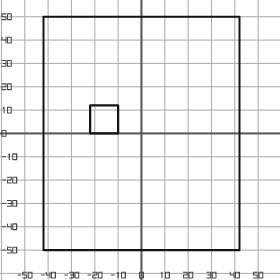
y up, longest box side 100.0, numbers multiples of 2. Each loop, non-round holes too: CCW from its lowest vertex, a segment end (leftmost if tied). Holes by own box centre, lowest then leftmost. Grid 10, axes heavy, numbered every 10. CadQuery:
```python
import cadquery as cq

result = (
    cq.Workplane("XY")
    .moveTo(-42.0, -50.0)
    .lineTo(42.0, -50.0)
    .lineTo(42.0, 50.0)
    .lineTo(-42.0, 50.0)
    .close()
    .moveTo(-22.0, 0.0)
    .lineTo(-10.0, 0.0)
    .lineTo(-10.0, 12.0)
    .lineTo(-22.0, 12.0)
    .close()
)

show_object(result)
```